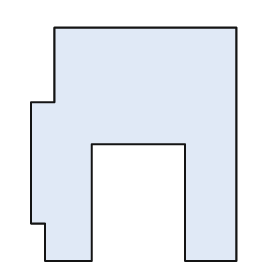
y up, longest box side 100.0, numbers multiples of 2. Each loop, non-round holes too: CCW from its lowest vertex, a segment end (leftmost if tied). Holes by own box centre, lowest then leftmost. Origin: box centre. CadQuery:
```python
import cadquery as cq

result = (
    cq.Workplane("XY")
    .moveTo(-38.0, -50.0)
    .lineTo(-18.0, -50.0)
    .lineTo(-18.0, 0.0)
    .lineTo(22.0, 0.0)
    .lineTo(22.0, -50.0)
    .lineTo(44.0, -50.0)
    .lineTo(44.0, 50.0)
    .lineTo(-34.0, 50.0)
    .lineTo(-34.0, 18.0)
    .lineTo(-44.0, 18.0)
    .lineTo(-44.0, -34.0)
    .lineTo(-38.0, -34.0)
    .close()
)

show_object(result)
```